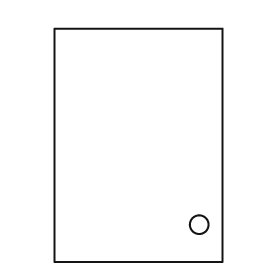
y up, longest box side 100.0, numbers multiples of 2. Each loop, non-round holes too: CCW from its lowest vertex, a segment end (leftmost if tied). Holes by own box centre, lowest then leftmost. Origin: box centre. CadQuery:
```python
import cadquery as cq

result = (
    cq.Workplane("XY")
    .moveTo(-36.0, -50.0)
    .lineTo(36.0, -50.0)
    .lineTo(36.0, 50.0)
    .lineTo(-36.0, 50.0)
    .close()
    .moveTo(26.0, -34.0)
    .circle(4.0)
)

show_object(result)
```